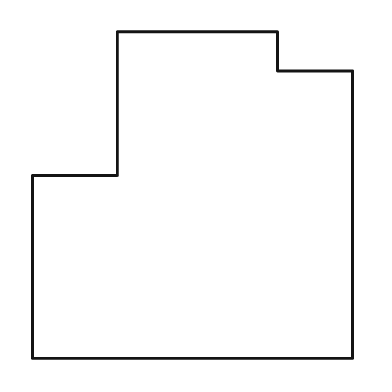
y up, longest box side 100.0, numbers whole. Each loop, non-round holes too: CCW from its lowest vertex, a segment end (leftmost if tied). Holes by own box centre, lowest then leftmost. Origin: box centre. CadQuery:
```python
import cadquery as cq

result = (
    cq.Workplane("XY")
    .moveTo(-49.0, -50.0)
    .lineTo(49.0, -50.0)
    .lineTo(49.0, 38.0)
    .lineTo(26.0, 38.0)
    .lineTo(26.0, 50.0)
    .lineTo(-23.0, 50.0)
    .lineTo(-23.0, 6.0)
    .lineTo(-49.0, 6.0)
    .close()
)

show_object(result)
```